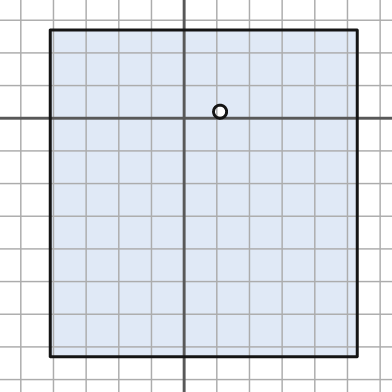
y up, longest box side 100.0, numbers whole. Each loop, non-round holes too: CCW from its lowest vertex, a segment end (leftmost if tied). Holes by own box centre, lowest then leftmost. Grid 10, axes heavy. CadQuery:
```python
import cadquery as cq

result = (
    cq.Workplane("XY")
    .moveTo(-41.0, -73.0)
    .lineTo(53.0, -73.0)
    .lineTo(53.0, 27.0)
    .lineTo(-41.0, 27.0)
    .close()
    .moveTo(11.0, 2.0)
    .circle(2.0)
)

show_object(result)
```